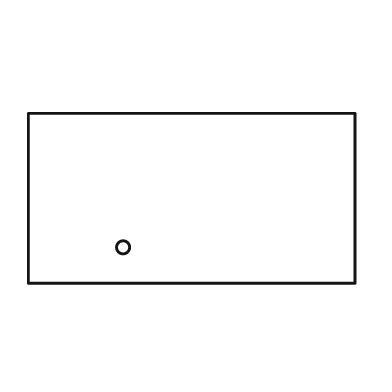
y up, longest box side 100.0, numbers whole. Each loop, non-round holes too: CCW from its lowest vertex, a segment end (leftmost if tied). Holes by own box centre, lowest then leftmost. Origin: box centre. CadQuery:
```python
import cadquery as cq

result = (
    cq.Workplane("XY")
    .moveTo(-50.0, -26.0)
    .lineTo(50.0, -26.0)
    .lineTo(50.0, 26.0)
    .lineTo(-50.0, 26.0)
    .close()
    .moveTo(-21.0, -15.0)
    .circle(2.0)
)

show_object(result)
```